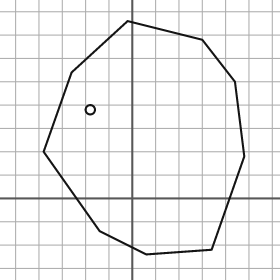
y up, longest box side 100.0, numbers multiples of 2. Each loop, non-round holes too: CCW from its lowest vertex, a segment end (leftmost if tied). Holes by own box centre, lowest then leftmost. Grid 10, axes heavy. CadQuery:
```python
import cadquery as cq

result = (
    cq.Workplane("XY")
    .moveTo(6.0, -24.0)
    .lineTo(34.0, -22.0)
    .lineTo(48.0, 18.0)
    .lineTo(44.0, 50.0)
    .lineTo(30.0, 68.0)
    .lineTo(-2.0, 76.0)
    .lineTo(-26.0, 54.0)
    .lineTo(-38.0, 20.0)
    .lineTo(-14.0, -14.0)
    .close()
    .moveTo(-18.0, 38.0)
    .circle(2.0)
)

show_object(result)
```